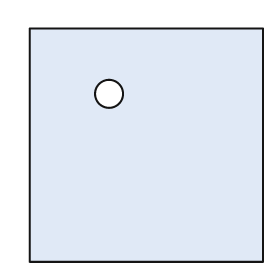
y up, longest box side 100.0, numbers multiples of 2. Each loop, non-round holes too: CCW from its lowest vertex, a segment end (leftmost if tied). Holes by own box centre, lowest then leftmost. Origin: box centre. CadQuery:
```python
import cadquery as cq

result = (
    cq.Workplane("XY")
    .moveTo(-50.0, -50.0)
    .lineTo(50.0, -50.0)
    .lineTo(50.0, 50.0)
    .lineTo(-50.0, 50.0)
    .close()
    .moveTo(-16.0, 22.0)
    .circle(6.0)
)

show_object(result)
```